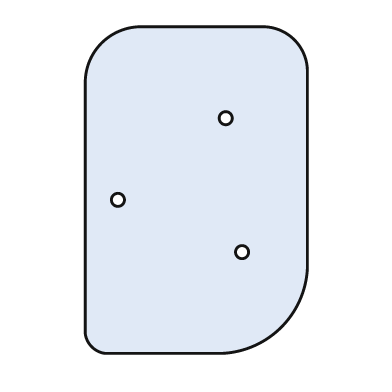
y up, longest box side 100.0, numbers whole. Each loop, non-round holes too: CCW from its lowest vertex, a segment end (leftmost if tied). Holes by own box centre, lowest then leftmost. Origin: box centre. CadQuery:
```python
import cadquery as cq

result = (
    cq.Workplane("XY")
    .moveTo(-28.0, -50.0)
    .lineTo(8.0, -50.0)
    .threePointArc((26.0, -42.0), (34.0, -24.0))
    .lineTo(34.0, 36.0)
    .threePointArc((30.0, 46.0), (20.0, 50.0))
    .lineTo(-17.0, 50.0)
    .threePointArc((-29.0, 45.0), (-34.0, 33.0))
    .lineTo(-34.0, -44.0)
    .threePointArc((-32.0, -48.0), (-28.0, -50.0))
    .close()
    .moveTo(14.0, -19.0)
    .circle(2.0)
    .moveTo(-24.0, -3.0)
    .circle(2.0)
    .moveTo(9.0, 22.0)
    .circle(2.0)
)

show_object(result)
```